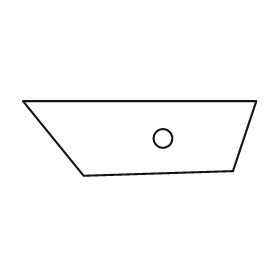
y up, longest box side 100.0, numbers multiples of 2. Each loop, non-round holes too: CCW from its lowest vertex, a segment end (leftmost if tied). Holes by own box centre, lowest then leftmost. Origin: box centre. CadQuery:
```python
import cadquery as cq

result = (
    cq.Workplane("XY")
    .moveTo(-24.0, -16.0)
    .lineTo(40.0, -14.0)
    .lineTo(50.0, 16.0)
    .lineTo(-50.0, 16.0)
    .close()
    .moveTo(10.0, 0.0)
    .circle(4.0)
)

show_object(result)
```